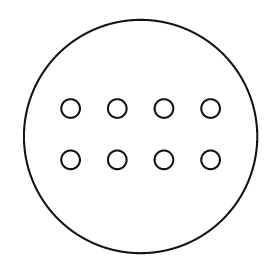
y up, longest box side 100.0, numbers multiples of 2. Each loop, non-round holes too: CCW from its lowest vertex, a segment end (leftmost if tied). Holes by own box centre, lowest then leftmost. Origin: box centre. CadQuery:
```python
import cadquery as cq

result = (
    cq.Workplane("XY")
    .moveTo(0.0, 0.0)
    .circle(50.0)
    .moveTo(-30.0, -10.0)
    .circle(4.0)
    .moveTo(-10.0, -10.0)
    .circle(4.0)
    .moveTo(10.0, -10.0)
    .circle(4.0)
    .moveTo(30.0, -10.0)
    .circle(4.0)
    .moveTo(-30.0, 12.0)
    .circle(4.0)
    .moveTo(-10.0, 12.0)
    .circle(4.0)
    .moveTo(10.0, 12.0)
    .circle(4.0)
    .moveTo(30.0, 12.0)
    .circle(4.0)
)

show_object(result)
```